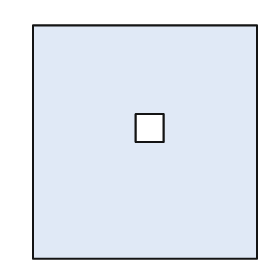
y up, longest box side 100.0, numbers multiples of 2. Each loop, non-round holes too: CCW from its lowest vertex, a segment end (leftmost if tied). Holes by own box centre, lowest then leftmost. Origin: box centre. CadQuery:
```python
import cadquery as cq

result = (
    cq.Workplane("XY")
    .moveTo(-48.0, -50.0)
    .lineTo(48.0, -50.0)
    .lineTo(48.0, 50.0)
    .lineTo(-48.0, 50.0)
    .close()
    .moveTo(-4.0, 0.0)
    .lineTo(8.0, 0.0)
    .lineTo(8.0, 12.0)
    .lineTo(-4.0, 12.0)
    .close()
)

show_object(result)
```